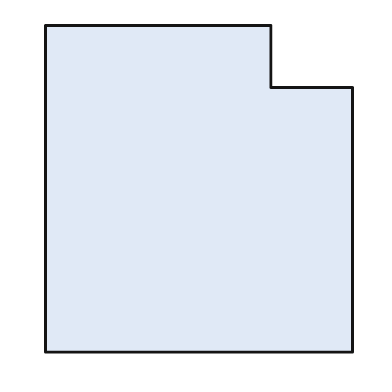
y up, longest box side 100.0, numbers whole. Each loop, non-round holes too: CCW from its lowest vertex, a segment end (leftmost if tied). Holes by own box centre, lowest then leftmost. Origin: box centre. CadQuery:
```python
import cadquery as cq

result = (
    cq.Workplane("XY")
    .moveTo(-47.0, -50.0)
    .lineTo(47.0, -50.0)
    .lineTo(47.0, 31.0)
    .lineTo(22.0, 31.0)
    .lineTo(22.0, 50.0)
    .lineTo(-47.0, 50.0)
    .close()
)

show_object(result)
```